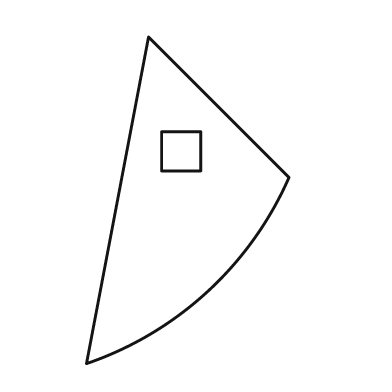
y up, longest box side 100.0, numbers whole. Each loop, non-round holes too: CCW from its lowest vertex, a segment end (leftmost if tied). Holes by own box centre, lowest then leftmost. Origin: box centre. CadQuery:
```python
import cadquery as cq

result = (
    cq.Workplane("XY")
    .moveTo(-31.0, -50.0)
    .threePointArc((6.0, -28.0), (31.0, 7.0))
    .lineTo(-12.0, 50.0)
    .close()
    .moveTo(-8.0, 9.0)
    .lineTo(4.0, 9.0)
    .lineTo(4.0, 21.0)
    .lineTo(-8.0, 21.0)
    .close()
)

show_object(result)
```